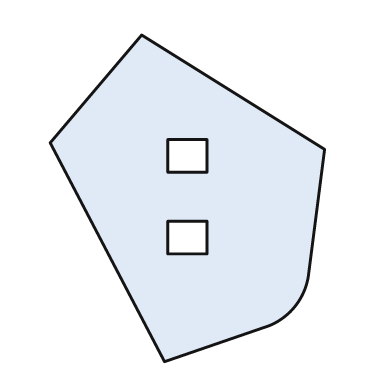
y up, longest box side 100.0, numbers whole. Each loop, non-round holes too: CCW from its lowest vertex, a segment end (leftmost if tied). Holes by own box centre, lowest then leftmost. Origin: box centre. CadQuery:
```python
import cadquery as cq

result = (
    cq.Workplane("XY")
    .moveTo(-7.0, -50.0)
    .lineTo(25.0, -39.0)
    .threePointArc((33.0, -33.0), (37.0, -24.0))
    .lineTo(42.0, 15.0)
    .lineTo(-14.0, 50.0)
    .lineTo(-42.0, 17.0)
    .close()
    .moveTo(-6.0, -17.0)
    .lineTo(6.0, -17.0)
    .lineTo(6.0, -7.0)
    .lineTo(-6.0, -7.0)
    .close()
    .moveTo(-6.0, 8.0)
    .lineTo(6.0, 8.0)
    .lineTo(6.0, 18.0)
    .lineTo(-6.0, 18.0)
    .close()
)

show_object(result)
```